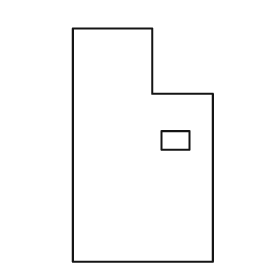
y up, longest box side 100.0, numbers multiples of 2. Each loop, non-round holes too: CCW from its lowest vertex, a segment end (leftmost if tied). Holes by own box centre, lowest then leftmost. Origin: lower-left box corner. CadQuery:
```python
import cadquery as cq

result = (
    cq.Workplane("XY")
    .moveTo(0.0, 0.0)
    .lineTo(60.0, 0.0)
    .lineTo(60.0, 72.0)
    .lineTo(34.0, 72.0)
    .lineTo(34.0, 100.0)
    .lineTo(0.0, 100.0)
    .close()
    .moveTo(38.0, 48.0)
    .lineTo(50.0, 48.0)
    .lineTo(50.0, 56.0)
    .lineTo(38.0, 56.0)
    .close()
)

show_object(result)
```